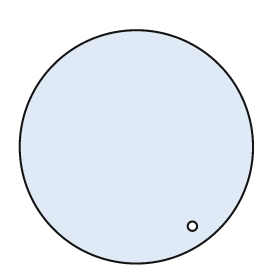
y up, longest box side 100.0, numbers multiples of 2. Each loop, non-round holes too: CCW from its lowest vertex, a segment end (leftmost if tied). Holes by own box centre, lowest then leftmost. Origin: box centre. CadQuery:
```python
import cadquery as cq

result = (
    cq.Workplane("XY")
    .moveTo(0.0, 0.0)
    .circle(50.0)
    .moveTo(24.0, -34.0)
    .circle(2.0)
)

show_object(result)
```